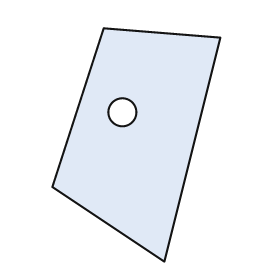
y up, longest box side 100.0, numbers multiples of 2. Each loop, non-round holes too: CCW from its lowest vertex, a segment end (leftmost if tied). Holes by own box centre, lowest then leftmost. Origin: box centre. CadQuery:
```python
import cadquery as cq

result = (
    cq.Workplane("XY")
    .moveTo(12.0, -50.0)
    .lineTo(36.0, 46.0)
    .lineTo(-14.0, 50.0)
    .lineTo(-36.0, -18.0)
    .close()
    .moveTo(-6.0, 14.0)
    .circle(6.0)
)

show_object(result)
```